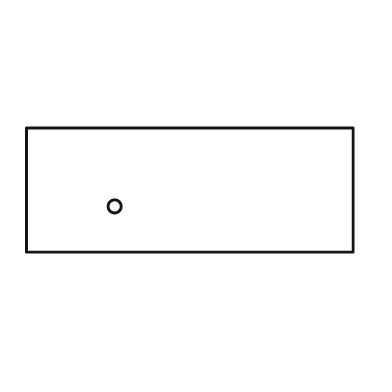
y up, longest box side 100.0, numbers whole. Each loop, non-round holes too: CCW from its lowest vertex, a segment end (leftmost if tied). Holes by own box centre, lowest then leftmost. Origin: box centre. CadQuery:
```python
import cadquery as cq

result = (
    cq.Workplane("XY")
    .moveTo(-50.0, -19.0)
    .lineTo(50.0, -19.0)
    .lineTo(50.0, 19.0)
    .lineTo(-50.0, 19.0)
    .close()
    .moveTo(-23.0, -5.0)
    .circle(2.0)
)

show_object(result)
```